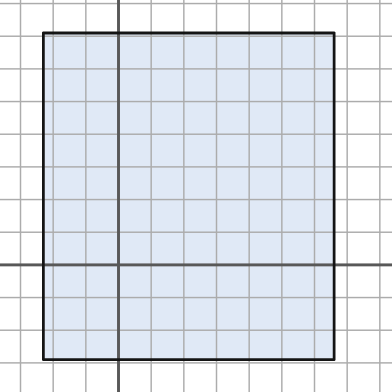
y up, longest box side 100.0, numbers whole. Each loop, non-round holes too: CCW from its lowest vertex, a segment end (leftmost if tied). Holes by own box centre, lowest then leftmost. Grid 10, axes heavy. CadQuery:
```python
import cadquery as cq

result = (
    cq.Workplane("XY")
    .moveTo(-23.0, -29.0)
    .lineTo(66.0, -29.0)
    .lineTo(66.0, 71.0)
    .lineTo(-23.0, 71.0)
    .close()
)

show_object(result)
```